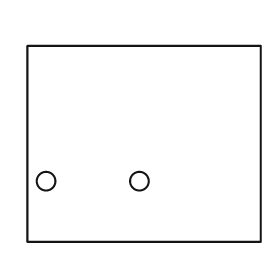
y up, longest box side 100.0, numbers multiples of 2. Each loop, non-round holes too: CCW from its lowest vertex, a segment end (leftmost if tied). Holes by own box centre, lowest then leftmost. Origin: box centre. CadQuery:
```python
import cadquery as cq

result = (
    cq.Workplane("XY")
    .moveTo(-50.0, -42.0)
    .lineTo(50.0, -42.0)
    .lineTo(50.0, 42.0)
    .lineTo(-50.0, 42.0)
    .close()
    .moveTo(-42.0, -16.0)
    .circle(4.0)
    .moveTo(-2.0, -16.0)
    .circle(4.0)
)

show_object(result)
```